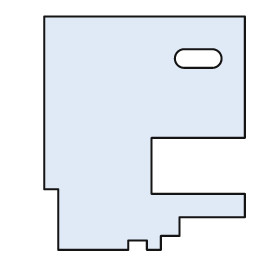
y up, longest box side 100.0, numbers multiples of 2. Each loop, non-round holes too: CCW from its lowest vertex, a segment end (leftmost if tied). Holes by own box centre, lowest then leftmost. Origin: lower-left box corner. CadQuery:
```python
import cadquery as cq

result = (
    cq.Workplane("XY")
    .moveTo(6.0, 0.0)
    .lineTo(36.0, 0.0)
    .lineTo(36.0, 4.0)
    .lineTo(44.0, 4.0)
    .lineTo(44.0, 0.0)
    .lineTo(50.0, 0.0)
    .lineTo(50.0, 6.0)
    .lineTo(58.0, 6.0)
    .lineTo(58.0, 14.0)
    .lineTo(86.0, 14.0)
    .lineTo(86.0, 24.0)
    .lineTo(46.0, 24.0)
    .lineTo(46.0, 48.0)
    .lineTo(86.0, 48.0)
    .lineTo(86.0, 100.0)
    .lineTo(0.0, 100.0)
    .lineTo(0.0, 26.0)
    .lineTo(6.0, 26.0)
    .close()
    .moveTo(60.0, 78.0)
    .lineTo(72.0, 78.0)
    .threePointArc((76.0, 82.0), (72.0, 86.0))
    .lineTo(60.0, 86.0)
    .threePointArc((56.0, 82.0), (60.0, 78.0))
    .close()
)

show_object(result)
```